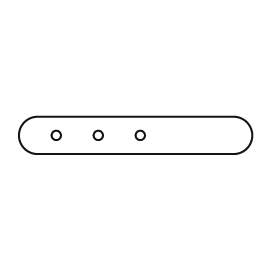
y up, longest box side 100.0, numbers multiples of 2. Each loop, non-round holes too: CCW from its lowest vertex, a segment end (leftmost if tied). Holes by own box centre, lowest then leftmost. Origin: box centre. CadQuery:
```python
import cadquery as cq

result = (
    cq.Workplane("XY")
    .moveTo(-42.0, -8.0)
    .lineTo(42.0, -8.0)
    .threePointArc((50.0, 0.0), (42.0, 8.0))
    .lineTo(-42.0, 8.0)
    .threePointArc((-50.0, 0.0), (-42.0, -8.0))
    .close()
    .moveTo(-34.0, 0.0)
    .circle(2.0)
    .moveTo(-16.0, 0.0)
    .circle(2.0)
    .moveTo(2.0, 0.0)
    .circle(2.0)
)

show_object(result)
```